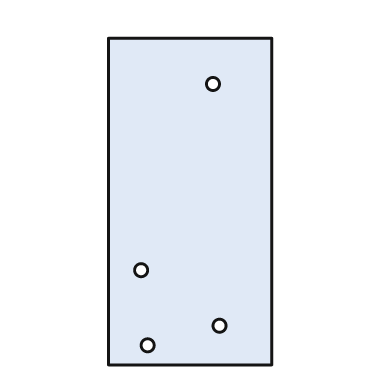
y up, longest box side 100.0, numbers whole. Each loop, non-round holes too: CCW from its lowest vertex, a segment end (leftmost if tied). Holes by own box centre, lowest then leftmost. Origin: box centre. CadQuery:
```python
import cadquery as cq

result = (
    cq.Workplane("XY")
    .moveTo(-25.0, -50.0)
    .lineTo(25.0, -50.0)
    .lineTo(25.0, 50.0)
    .lineTo(-25.0, 50.0)
    .close()
    .moveTo(-13.0, -44.0)
    .circle(2.0)
    .moveTo(9.0, -38.0)
    .circle(2.0)
    .moveTo(-15.0, -21.0)
    .circle(2.0)
    .moveTo(7.0, 36.0)
    .circle(2.0)
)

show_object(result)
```